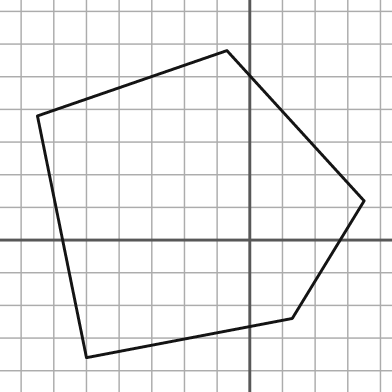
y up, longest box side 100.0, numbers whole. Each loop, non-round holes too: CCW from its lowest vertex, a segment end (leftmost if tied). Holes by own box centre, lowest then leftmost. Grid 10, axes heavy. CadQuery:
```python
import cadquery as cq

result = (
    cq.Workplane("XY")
    .moveTo(-50.0, -36.0)
    .lineTo(13.0, -24.0)
    .lineTo(35.0, 12.0)
    .lineTo(-7.0, 58.0)
    .lineTo(-65.0, 38.0)
    .close()
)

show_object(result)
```